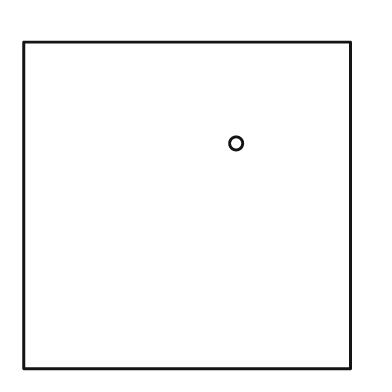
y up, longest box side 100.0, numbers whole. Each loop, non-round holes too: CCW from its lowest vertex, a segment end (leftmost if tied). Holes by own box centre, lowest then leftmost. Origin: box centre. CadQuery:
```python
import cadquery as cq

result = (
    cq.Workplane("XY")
    .moveTo(-50.0, -50.0)
    .lineTo(50.0, -50.0)
    .lineTo(50.0, 50.0)
    .lineTo(-50.0, 50.0)
    .close()
    .moveTo(15.0, 19.0)
    .circle(2.0)
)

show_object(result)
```